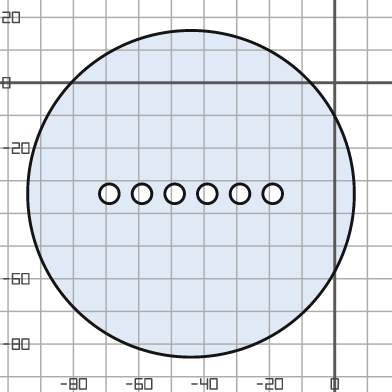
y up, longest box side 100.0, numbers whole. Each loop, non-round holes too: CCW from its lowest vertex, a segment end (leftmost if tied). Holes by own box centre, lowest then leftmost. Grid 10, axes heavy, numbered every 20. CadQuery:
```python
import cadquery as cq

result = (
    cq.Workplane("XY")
    .moveTo(-44.0, -34.0)
    .circle(50.0)
    .moveTo(-69.0, -34.0)
    .circle(3.0)
    .moveTo(-59.0, -34.0)
    .circle(3.0)
    .moveTo(-49.0, -34.0)
    .circle(3.0)
    .moveTo(-39.0, -34.0)
    .circle(3.0)
    .moveTo(-29.0, -34.0)
    .circle(3.0)
    .moveTo(-19.0, -34.0)
    .circle(3.0)
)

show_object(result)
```